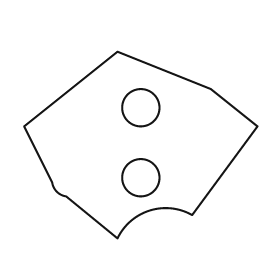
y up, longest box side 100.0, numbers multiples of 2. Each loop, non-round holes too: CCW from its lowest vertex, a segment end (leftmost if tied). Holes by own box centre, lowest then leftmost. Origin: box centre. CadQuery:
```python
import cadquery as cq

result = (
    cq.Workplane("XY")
    .moveTo(-10.0, -40.0)
    .threePointArc((4.0, -28.0), (22.0, -30.0))
    .lineTo(50.0, 8.0)
    .lineTo(30.0, 24.0)
    .lineTo(-10.0, 40.0)
    .lineTo(-50.0, 8.0)
    .lineTo(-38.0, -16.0)
    .threePointArc((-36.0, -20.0), (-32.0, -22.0))
    .close()
    .moveTo(0.0, -14.0)
    .circle(8.0)
    .moveTo(0.0, 16.0)
    .circle(8.0)
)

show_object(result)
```